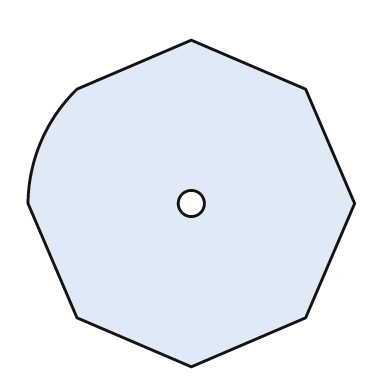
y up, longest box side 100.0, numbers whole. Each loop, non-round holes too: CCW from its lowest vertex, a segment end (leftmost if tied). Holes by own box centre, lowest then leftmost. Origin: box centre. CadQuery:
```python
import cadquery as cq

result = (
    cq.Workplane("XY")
    .moveTo(0.0, -50.0)
    .lineTo(35.0, -35.0)
    .lineTo(50.0, 0.0)
    .lineTo(35.0, 35.0)
    .lineTo(0.0, 50.0)
    .lineTo(-35.0, 35.0)
    .threePointArc((-46.0, 19.0), (-50.0, 0.0))
    .lineTo(-35.0, -35.0)
    .close()
    .moveTo(0.0, 0.0)
    .circle(4.0)
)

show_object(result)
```